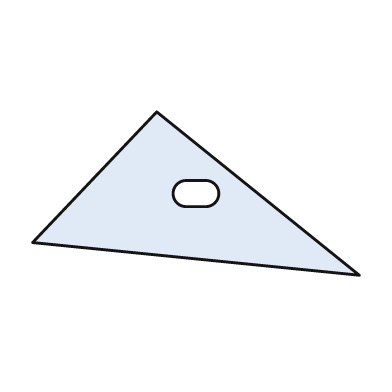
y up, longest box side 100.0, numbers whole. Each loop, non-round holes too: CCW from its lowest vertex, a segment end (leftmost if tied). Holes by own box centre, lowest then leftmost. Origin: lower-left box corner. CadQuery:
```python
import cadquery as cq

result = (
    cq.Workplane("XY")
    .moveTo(100.0, 0.0)
    .lineTo(38.0, 50.0)
    .lineTo(0.0, 10.0)
    .close()
    .moveTo(47.0, 21.0)
    .lineTo(53.0, 21.0)
    .threePointArc((57.0, 25.0), (53.0, 29.0))
    .lineTo(47.0, 29.0)
    .threePointArc((43.0, 25.0), (47.0, 21.0))
    .close()
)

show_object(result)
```